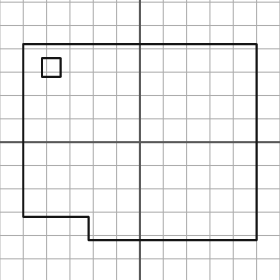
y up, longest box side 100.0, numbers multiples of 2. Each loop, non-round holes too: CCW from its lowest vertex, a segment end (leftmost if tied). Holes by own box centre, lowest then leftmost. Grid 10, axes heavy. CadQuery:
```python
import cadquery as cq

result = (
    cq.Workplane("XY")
    .moveTo(-22.0, -42.0)
    .lineTo(50.0, -42.0)
    .lineTo(50.0, 42.0)
    .lineTo(-50.0, 42.0)
    .lineTo(-50.0, -32.0)
    .lineTo(-22.0, -32.0)
    .close()
    .moveTo(-42.0, 28.0)
    .lineTo(-34.0, 28.0)
    .lineTo(-34.0, 36.0)
    .lineTo(-42.0, 36.0)
    .close()
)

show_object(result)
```